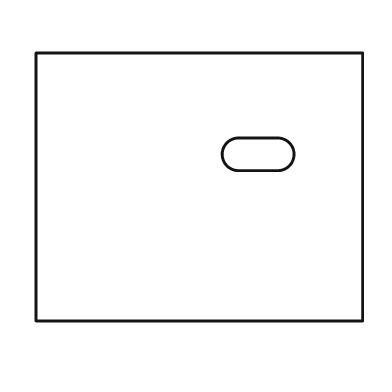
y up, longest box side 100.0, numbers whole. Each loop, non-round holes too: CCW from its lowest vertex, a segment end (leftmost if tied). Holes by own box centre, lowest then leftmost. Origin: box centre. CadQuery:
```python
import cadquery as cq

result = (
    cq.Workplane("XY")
    .moveTo(-50.0, -41.0)
    .lineTo(50.0, -41.0)
    .lineTo(50.0, 41.0)
    .lineTo(-50.0, 41.0)
    .close()
    .moveTo(12.0, 5.0)
    .lineTo(24.0, 5.0)
    .threePointArc((29.0, 10.0), (24.0, 15.0))
    .lineTo(12.0, 15.0)
    .threePointArc((7.0, 10.0), (12.0, 5.0))
    .close()
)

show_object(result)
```